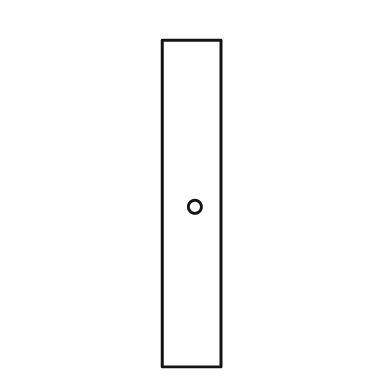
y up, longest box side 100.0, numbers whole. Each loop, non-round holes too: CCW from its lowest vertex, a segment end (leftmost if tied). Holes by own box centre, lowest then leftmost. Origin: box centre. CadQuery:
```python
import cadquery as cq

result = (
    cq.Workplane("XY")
    .moveTo(-9.0, -50.0)
    .lineTo(9.0, -50.0)
    .lineTo(9.0, 50.0)
    .lineTo(-9.0, 50.0)
    .close()
    .moveTo(1.0, -1.0)
    .circle(2.0)
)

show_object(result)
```